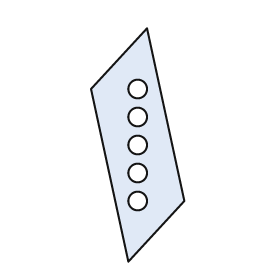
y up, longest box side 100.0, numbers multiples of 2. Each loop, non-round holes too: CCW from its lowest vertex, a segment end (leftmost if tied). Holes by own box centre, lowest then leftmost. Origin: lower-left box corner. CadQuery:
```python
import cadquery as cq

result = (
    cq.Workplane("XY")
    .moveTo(16.0, 0.0)
    .lineTo(40.0, 26.0)
    .lineTo(24.0, 100.0)
    .lineTo(0.0, 74.0)
    .close()
    .moveTo(20.0, 26.0)
    .circle(4.0)
    .moveTo(20.0, 38.0)
    .circle(4.0)
    .moveTo(20.0, 50.0)
    .circle(4.0)
    .moveTo(20.0, 62.0)
    .circle(4.0)
    .moveTo(20.0, 74.0)
    .circle(4.0)
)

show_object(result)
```